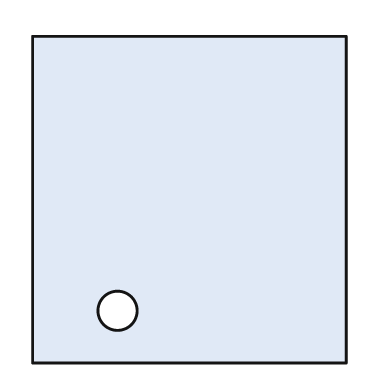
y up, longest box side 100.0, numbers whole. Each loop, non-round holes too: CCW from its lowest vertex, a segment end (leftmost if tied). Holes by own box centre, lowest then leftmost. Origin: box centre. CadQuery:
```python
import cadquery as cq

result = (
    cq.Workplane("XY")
    .moveTo(-48.0, -50.0)
    .lineTo(48.0, -50.0)
    .lineTo(48.0, 50.0)
    .lineTo(-48.0, 50.0)
    .close()
    .moveTo(-22.0, -34.0)
    .circle(6.0)
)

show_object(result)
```